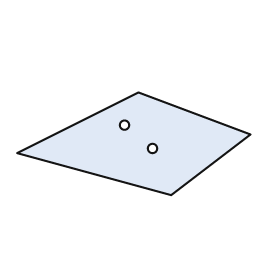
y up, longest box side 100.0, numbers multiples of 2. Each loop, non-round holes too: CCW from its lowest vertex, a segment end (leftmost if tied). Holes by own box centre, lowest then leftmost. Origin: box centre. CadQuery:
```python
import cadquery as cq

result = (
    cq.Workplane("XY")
    .moveTo(16.0, -22.0)
    .lineTo(50.0, 4.0)
    .lineTo(2.0, 22.0)
    .lineTo(-50.0, -4.0)
    .close()
    .moveTo(8.0, -2.0)
    .circle(2.0)
    .moveTo(-4.0, 8.0)
    .circle(2.0)
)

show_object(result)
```